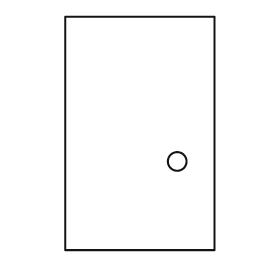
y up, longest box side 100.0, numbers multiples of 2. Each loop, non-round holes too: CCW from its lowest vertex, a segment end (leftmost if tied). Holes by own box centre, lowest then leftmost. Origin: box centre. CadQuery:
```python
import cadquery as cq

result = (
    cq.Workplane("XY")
    .moveTo(-32.0, -50.0)
    .lineTo(32.0, -50.0)
    .lineTo(32.0, 50.0)
    .lineTo(-32.0, 50.0)
    .close()
    .moveTo(16.0, -12.0)
    .circle(4.0)
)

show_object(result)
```